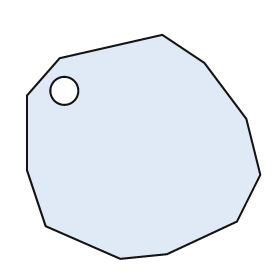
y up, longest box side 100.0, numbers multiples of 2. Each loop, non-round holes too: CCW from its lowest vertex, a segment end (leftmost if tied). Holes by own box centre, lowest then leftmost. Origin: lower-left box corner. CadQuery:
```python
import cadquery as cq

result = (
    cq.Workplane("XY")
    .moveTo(40.0, 0.0)
    .lineTo(60.0, 2.0)
    .lineTo(90.0, 16.0)
    .lineTo(100.0, 36.0)
    .lineTo(94.0, 60.0)
    .lineTo(76.0, 84.0)
    .lineTo(58.0, 96.0)
    .lineTo(14.0, 86.0)
    .lineTo(0.0, 70.0)
    .lineTo(0.0, 38.0)
    .lineTo(8.0, 14.0)
    .close()
    .moveTo(16.0, 72.0)
    .circle(6.0)
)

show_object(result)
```